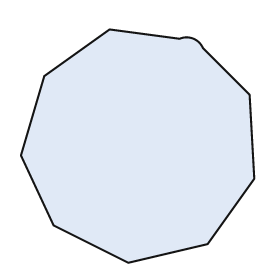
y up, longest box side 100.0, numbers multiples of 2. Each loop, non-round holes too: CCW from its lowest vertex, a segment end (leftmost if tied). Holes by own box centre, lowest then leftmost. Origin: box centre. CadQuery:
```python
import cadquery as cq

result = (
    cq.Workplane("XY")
    .moveTo(-4.0, -50.0)
    .lineTo(30.0, -42.0)
    .lineTo(50.0, -14.0)
    .lineTo(48.0, 22.0)
    .lineTo(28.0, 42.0)
    .threePointArc((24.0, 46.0), (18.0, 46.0))
    .lineTo(-12.0, 50.0)
    .lineTo(-40.0, 30.0)
    .lineTo(-50.0, -4.0)
    .lineTo(-36.0, -34.0)
    .close()
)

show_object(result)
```